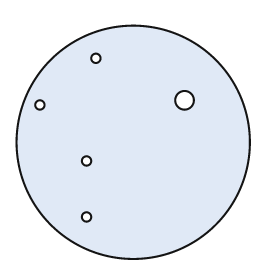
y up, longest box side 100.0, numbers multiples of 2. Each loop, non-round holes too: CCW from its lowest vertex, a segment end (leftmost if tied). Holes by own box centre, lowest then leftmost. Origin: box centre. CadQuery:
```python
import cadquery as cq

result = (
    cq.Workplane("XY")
    .moveTo(0.0, 0.0)
    .circle(50.0)
    .moveTo(-20.0, -32.0)
    .circle(2.0)
    .moveTo(-20.0, -8.0)
    .circle(2.0)
    .moveTo(-40.0, 16.0)
    .circle(2.0)
    .moveTo(22.0, 18.0)
    .circle(4.0)
    .moveTo(-16.0, 36.0)
    .circle(2.0)
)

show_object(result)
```